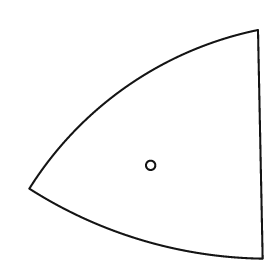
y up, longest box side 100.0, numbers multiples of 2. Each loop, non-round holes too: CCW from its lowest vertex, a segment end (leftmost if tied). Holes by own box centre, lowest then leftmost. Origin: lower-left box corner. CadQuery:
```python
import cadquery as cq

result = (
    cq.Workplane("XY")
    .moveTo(100.0, 0.0)
    .lineTo(98.0, 98.0)
    .threePointArc((42.0, 74.0), (0.0, 30.0))
    .threePointArc((48.0, 8.0), (100.0, 0.0))
    .close()
    .moveTo(52.0, 40.0)
    .circle(2.0)
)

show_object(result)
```